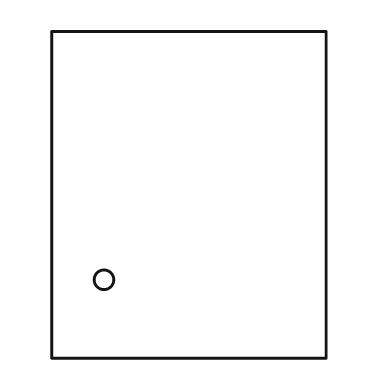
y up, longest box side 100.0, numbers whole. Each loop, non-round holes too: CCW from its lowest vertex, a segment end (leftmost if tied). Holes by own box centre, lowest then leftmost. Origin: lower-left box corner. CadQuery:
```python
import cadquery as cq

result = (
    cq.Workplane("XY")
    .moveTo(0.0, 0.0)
    .lineTo(84.0, 0.0)
    .lineTo(84.0, 100.0)
    .lineTo(0.0, 100.0)
    .close()
    .moveTo(16.0, 24.0)
    .circle(3.0)
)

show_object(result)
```